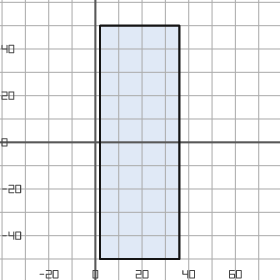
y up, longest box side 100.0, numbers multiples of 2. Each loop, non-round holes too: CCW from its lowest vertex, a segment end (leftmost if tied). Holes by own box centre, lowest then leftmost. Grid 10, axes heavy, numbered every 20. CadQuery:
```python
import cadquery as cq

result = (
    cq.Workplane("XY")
    .moveTo(2.0, -50.0)
    .lineTo(36.0, -50.0)
    .lineTo(36.0, 50.0)
    .lineTo(2.0, 50.0)
    .close()
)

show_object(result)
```